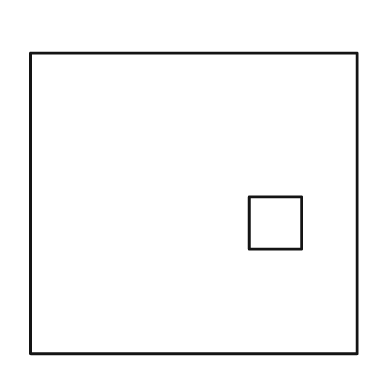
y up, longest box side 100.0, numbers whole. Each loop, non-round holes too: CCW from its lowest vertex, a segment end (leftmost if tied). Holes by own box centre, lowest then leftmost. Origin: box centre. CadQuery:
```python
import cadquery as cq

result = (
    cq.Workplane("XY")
    .moveTo(-50.0, -46.0)
    .lineTo(50.0, -46.0)
    .lineTo(50.0, 46.0)
    .lineTo(-50.0, 46.0)
    .close()
    .moveTo(17.0, -14.0)
    .lineTo(33.0, -14.0)
    .lineTo(33.0, 2.0)
    .lineTo(17.0, 2.0)
    .close()
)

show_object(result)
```